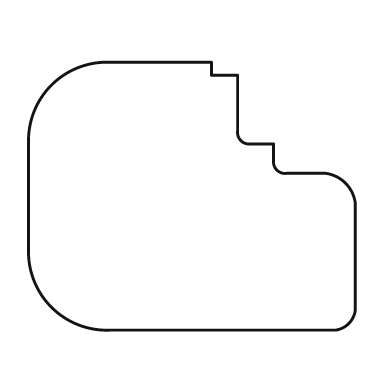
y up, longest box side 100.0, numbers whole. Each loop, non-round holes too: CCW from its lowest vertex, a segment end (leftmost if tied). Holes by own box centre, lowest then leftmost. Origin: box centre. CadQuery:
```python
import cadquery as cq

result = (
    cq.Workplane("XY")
    .moveTo(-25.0, -41.0)
    .lineTo(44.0, -41.0)
    .threePointArc((48.0, -39.0), (50.0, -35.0))
    .lineTo(50.0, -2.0)
    .threePointArc((47.0, 4.0), (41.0, 7.0))
    .lineTo(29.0, 7.0)
    .threePointArc((26.0, 8.0), (25.0, 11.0))
    .lineTo(25.0, 16.0)
    .lineTo(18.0, 16.0)
    .threePointArc((15.0, 17.0), (14.0, 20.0))
    .lineTo(14.0, 37.0)
    .lineTo(6.0, 37.0)
    .lineTo(6.0, 41.0)
    .lineTo(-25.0, 41.0)
    .threePointArc((-43.0, 34.0), (-50.0, 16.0))
    .lineTo(-50.0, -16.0)
    .threePointArc((-43.0, -34.0), (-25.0, -41.0))
    .close()
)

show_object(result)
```